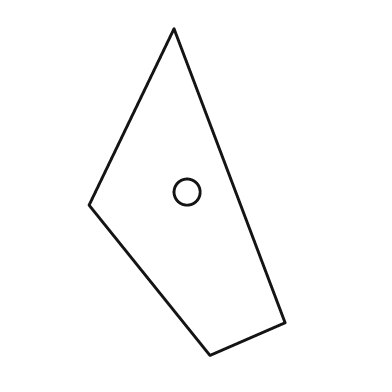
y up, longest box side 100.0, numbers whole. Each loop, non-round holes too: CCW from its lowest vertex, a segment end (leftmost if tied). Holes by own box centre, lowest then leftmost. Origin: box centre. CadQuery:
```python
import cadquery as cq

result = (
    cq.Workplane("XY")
    .moveTo(7.0, -50.0)
    .lineTo(30.0, -40.0)
    .lineTo(-4.0, 50.0)
    .lineTo(-30.0, -4.0)
    .close()
    .moveTo(0.0, 0.0)
    .circle(4.0)
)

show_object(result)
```